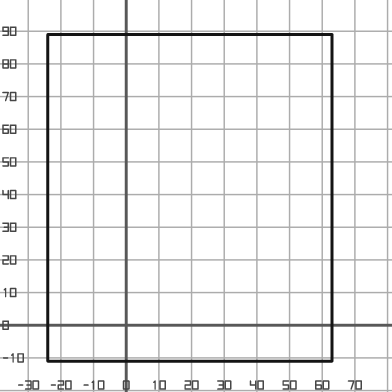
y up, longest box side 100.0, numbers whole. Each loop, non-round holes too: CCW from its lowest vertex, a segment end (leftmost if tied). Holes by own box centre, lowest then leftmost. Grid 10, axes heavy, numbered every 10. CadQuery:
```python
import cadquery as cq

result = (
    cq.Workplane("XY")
    .moveTo(-24.0, -11.0)
    .lineTo(63.0, -11.0)
    .lineTo(63.0, 89.0)
    .lineTo(-24.0, 89.0)
    .close()
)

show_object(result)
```